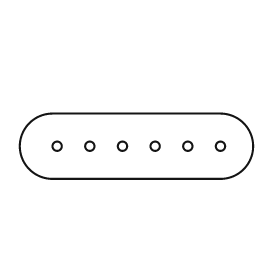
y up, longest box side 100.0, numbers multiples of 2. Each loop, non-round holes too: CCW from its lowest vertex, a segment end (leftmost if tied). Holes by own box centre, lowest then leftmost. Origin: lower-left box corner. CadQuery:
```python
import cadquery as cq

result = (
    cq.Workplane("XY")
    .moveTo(14.0, 0.0)
    .lineTo(86.0, 0.0)
    .threePointArc((100.0, 14.0), (86.0, 28.0))
    .lineTo(14.0, 28.0)
    .threePointArc((0.0, 14.0), (14.0, 0.0))
    .close()
    .moveTo(16.0, 14.0)
    .circle(2.0)
    .moveTo(30.0, 14.0)
    .circle(2.0)
    .moveTo(44.0, 14.0)
    .circle(2.0)
    .moveTo(58.0, 14.0)
    .circle(2.0)
    .moveTo(72.0, 14.0)
    .circle(2.0)
    .moveTo(86.0, 14.0)
    .circle(2.0)
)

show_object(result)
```